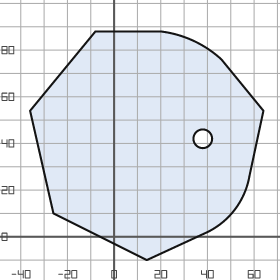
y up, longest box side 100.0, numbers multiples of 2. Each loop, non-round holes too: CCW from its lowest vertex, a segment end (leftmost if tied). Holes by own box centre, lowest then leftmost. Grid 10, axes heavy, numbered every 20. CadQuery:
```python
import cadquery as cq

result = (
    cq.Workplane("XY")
    .moveTo(14.0, -10.0)
    .lineTo(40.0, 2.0)
    .threePointArc((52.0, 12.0), (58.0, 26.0))
    .lineTo(64.0, 54.0)
    .lineTo(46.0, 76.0)
    .threePointArc((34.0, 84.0), (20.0, 88.0))
    .lineTo(-8.0, 88.0)
    .lineTo(-36.0, 54.0)
    .lineTo(-26.0, 10.0)
    .close()
    .moveTo(38.0, 42.0)
    .circle(4.0)
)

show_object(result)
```